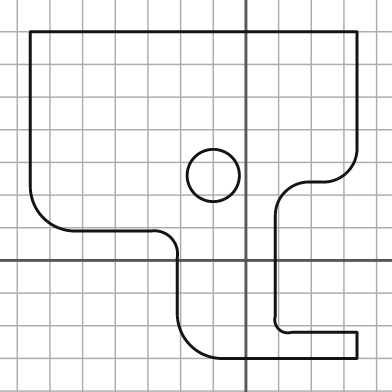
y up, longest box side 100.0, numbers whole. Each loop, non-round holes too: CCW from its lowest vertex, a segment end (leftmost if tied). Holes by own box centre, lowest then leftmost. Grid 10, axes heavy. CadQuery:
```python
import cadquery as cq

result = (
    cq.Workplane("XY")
    .moveTo(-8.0, -30.0)
    .lineTo(34.0, -30.0)
    .lineTo(34.0, -22.0)
    .lineTo(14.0, -22.0)
    .threePointArc((10.0, -21.0), (9.0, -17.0))
    .lineTo(9.0, 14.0)
    .threePointArc((12.0, 21.0), (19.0, 24.0))
    .lineTo(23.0, 24.0)
    .threePointArc((31.0, 27.0), (34.0, 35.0))
    .lineTo(34.0, 70.0)
    .lineTo(-66.0, 70.0)
    .lineTo(-66.0, 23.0)
    .threePointArc((-62.0, 13.0), (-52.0, 9.0))
    .lineTo(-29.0, 9.0)
    .threePointArc((-23.0, 7.0), (-21.0, 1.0))
    .lineTo(-21.0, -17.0)
    .threePointArc((-17.0, -26.0), (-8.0, -30.0))
    .close()
    .moveTo(-10.0, 26.0)
    .circle(8.0)
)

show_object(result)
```